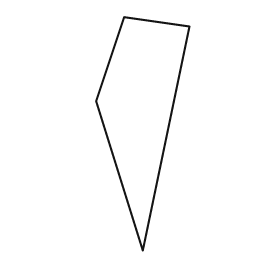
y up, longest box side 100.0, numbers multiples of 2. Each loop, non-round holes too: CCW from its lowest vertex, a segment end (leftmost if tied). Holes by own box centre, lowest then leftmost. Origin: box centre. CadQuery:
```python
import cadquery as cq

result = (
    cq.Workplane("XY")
    .moveTo(0.0, -50.0)
    .lineTo(20.0, 46.0)
    .lineTo(-8.0, 50.0)
    .lineTo(-20.0, 14.0)
    .close()
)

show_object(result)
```